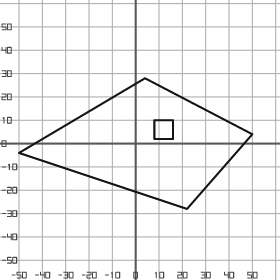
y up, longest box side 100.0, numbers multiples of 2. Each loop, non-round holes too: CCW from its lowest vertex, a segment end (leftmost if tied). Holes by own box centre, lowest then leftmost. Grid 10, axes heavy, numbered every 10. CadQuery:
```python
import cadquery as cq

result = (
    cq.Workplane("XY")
    .moveTo(22.0, -28.0)
    .lineTo(50.0, 4.0)
    .lineTo(4.0, 28.0)
    .lineTo(-50.0, -4.0)
    .close()
    .moveTo(8.0, 2.0)
    .lineTo(16.0, 2.0)
    .lineTo(16.0, 10.0)
    .lineTo(8.0, 10.0)
    .close()
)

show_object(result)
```